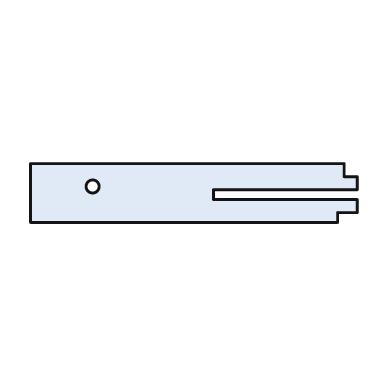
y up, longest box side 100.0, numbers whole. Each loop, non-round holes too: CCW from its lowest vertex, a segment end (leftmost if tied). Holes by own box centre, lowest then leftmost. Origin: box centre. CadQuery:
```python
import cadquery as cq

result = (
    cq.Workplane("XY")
    .moveTo(-50.0, -9.0)
    .lineTo(44.0, -9.0)
    .lineTo(44.0, -6.0)
    .lineTo(50.0, -6.0)
    .lineTo(50.0, -2.0)
    .lineTo(6.0, -2.0)
    .lineTo(6.0, 1.0)
    .lineTo(50.0, 1.0)
    .lineTo(50.0, 5.0)
    .lineTo(46.0, 5.0)
    .lineTo(46.0, 9.0)
    .lineTo(-50.0, 9.0)
    .close()
    .moveTo(-31.0, 2.0)
    .circle(2.0)
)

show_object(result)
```